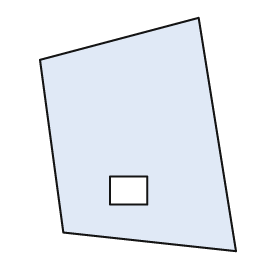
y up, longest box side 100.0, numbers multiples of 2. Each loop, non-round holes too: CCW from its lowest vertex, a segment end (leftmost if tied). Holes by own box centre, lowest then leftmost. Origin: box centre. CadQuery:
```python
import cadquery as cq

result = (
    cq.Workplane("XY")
    .moveTo(42.0, -50.0)
    .lineTo(26.0, 50.0)
    .lineTo(-42.0, 32.0)
    .lineTo(-32.0, -42.0)
    .close()
    .moveTo(-12.0, -30.0)
    .lineTo(4.0, -30.0)
    .lineTo(4.0, -18.0)
    .lineTo(-12.0, -18.0)
    .close()
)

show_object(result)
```